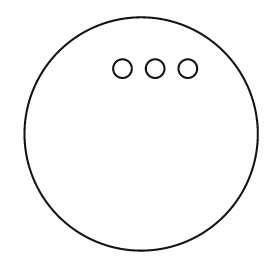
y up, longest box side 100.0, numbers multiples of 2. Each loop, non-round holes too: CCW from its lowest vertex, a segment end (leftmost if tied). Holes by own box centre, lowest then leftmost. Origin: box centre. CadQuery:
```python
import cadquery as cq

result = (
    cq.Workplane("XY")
    .moveTo(0.0, 0.0)
    .circle(50.0)
    .moveTo(-8.0, 28.0)
    .circle(4.0)
    .moveTo(6.0, 28.0)
    .circle(4.0)
    .moveTo(20.0, 28.0)
    .circle(4.0)
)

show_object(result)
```